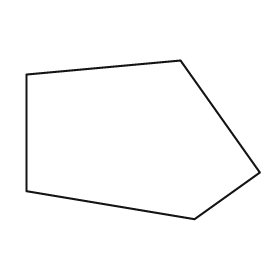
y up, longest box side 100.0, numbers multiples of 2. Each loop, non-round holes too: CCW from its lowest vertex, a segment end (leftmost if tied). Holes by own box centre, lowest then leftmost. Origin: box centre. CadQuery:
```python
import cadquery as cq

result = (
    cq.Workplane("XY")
    .moveTo(22.0, -34.0)
    .lineTo(50.0, -14.0)
    .lineTo(16.0, 34.0)
    .lineTo(-50.0, 28.0)
    .lineTo(-50.0, -22.0)
    .close()
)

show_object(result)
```